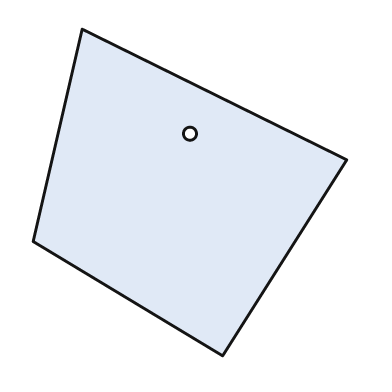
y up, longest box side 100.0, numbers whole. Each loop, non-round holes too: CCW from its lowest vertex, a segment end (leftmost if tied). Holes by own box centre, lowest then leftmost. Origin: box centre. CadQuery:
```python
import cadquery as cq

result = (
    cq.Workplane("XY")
    .moveTo(10.0, -50.0)
    .lineTo(48.0, 10.0)
    .lineTo(-33.0, 50.0)
    .lineTo(-48.0, -15.0)
    .close()
    .moveTo(0.0, 18.0)
    .circle(2.0)
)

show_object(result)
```